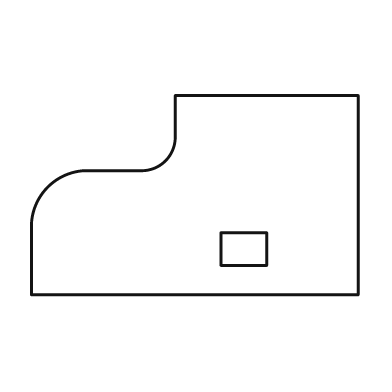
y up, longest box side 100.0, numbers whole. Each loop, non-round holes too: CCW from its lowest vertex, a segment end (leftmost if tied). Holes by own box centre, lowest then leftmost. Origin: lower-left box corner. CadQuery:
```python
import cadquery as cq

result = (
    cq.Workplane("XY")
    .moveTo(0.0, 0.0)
    .lineTo(100.0, 0.0)
    .lineTo(100.0, 61.0)
    .lineTo(44.0, 61.0)
    .lineTo(44.0, 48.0)
    .threePointArc((41.0, 41.0), (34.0, 38.0))
    .lineTo(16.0, 38.0)
    .threePointArc((5.0, 33.0), (0.0, 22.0))
    .close()
    .moveTo(58.0, 9.0)
    .lineTo(72.0, 9.0)
    .lineTo(72.0, 19.0)
    .lineTo(58.0, 19.0)
    .close()
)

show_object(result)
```